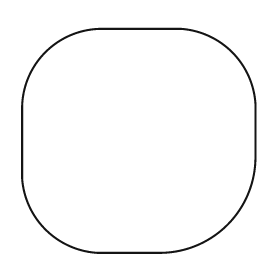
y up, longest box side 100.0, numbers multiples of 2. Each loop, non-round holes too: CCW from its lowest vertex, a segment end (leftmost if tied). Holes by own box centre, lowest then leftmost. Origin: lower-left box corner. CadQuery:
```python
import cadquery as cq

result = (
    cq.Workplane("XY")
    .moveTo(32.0, 0.0)
    .lineTo(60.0, 0.0)
    .threePointArc((88.0, 12.0), (100.0, 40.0))
    .lineTo(100.0, 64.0)
    .threePointArc((90.0, 86.0), (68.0, 96.0))
    .lineTo(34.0, 96.0)
    .threePointArc((10.0, 86.0), (0.0, 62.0))
    .lineTo(0.0, 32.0)
    .threePointArc((10.0, 10.0), (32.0, 0.0))
    .close()
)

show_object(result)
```